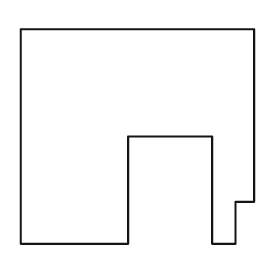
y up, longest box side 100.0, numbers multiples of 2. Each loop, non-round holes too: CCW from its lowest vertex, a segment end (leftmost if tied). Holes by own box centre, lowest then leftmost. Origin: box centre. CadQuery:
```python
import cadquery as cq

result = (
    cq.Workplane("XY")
    .moveTo(-50.0, -46.0)
    .lineTo(-4.0, -46.0)
    .lineTo(-4.0, 0.0)
    .lineTo(32.0, 0.0)
    .lineTo(32.0, -46.0)
    .lineTo(42.0, -46.0)
    .lineTo(42.0, -28.0)
    .lineTo(50.0, -28.0)
    .lineTo(50.0, 46.0)
    .lineTo(-50.0, 46.0)
    .close()
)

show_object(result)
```